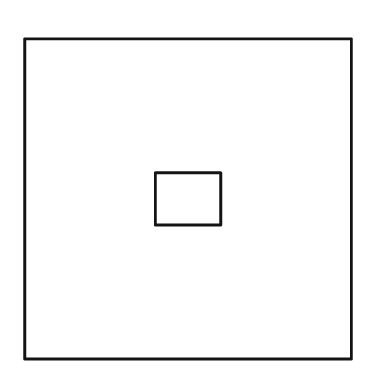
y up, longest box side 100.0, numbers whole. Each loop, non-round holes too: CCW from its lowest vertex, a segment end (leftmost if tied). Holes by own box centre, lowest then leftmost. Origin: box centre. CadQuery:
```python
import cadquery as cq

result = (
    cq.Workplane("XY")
    .moveTo(-50.0, -49.0)
    .lineTo(50.0, -49.0)
    .lineTo(50.0, 49.0)
    .lineTo(-50.0, 49.0)
    .close()
    .moveTo(-10.0, -8.0)
    .lineTo(10.0, -8.0)
    .lineTo(10.0, 8.0)
    .lineTo(-10.0, 8.0)
    .close()
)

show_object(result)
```